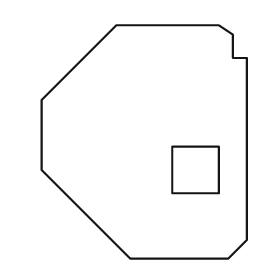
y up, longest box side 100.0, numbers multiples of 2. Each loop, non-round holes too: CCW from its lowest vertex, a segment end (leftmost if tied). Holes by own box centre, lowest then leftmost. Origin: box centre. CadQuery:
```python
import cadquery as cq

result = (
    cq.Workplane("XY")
    .moveTo(-6.0, -50.0)
    .lineTo(36.0, -50.0)
    .lineTo(44.0, -42.0)
    .lineTo(44.0, 36.0)
    .lineTo(38.0, 36.0)
    .lineTo(38.0, 46.0)
    .lineTo(32.0, 50.0)
    .lineTo(-12.0, 50.0)
    .lineTo(-44.0, 18.0)
    .lineTo(-44.0, -12.0)
    .close()
    .moveTo(12.0, -22.0)
    .lineTo(32.0, -22.0)
    .lineTo(32.0, -2.0)
    .lineTo(12.0, -2.0)
    .close()
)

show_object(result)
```